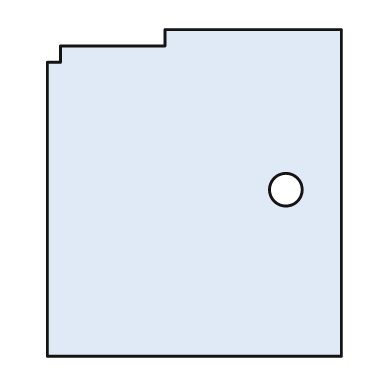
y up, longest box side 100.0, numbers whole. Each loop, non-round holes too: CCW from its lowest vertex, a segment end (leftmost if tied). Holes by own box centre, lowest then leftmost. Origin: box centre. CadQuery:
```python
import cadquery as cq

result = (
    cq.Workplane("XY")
    .moveTo(-45.0, -50.0)
    .lineTo(45.0, -50.0)
    .lineTo(45.0, 50.0)
    .lineTo(-9.0, 50.0)
    .lineTo(-9.0, 45.0)
    .lineTo(-41.0, 45.0)
    .lineTo(-41.0, 40.0)
    .lineTo(-45.0, 40.0)
    .close()
    .moveTo(28.0, 1.0)
    .circle(5.0)
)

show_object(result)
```